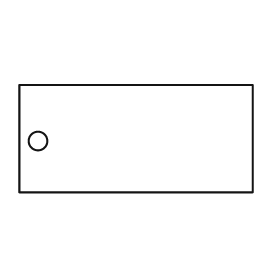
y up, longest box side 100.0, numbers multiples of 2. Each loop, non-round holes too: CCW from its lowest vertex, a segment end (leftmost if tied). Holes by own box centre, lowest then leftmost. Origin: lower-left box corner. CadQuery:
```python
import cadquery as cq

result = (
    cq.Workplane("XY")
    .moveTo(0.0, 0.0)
    .lineTo(100.0, 0.0)
    .lineTo(100.0, 46.0)
    .lineTo(0.0, 46.0)
    .close()
    .moveTo(8.0, 22.0)
    .circle(4.0)
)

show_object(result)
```